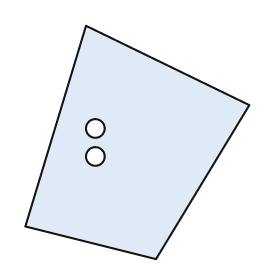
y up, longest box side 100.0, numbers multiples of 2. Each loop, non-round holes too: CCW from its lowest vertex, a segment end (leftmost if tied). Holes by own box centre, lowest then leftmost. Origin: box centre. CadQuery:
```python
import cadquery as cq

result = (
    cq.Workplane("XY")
    .moveTo(8.0, -50.0)
    .lineTo(48.0, 16.0)
    .lineTo(-22.0, 50.0)
    .lineTo(-48.0, -36.0)
    .close()
    .moveTo(-18.0, -6.0)
    .circle(4.0)
    .moveTo(-18.0, 6.0)
    .circle(4.0)
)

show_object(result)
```